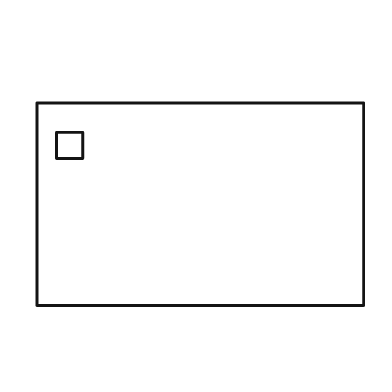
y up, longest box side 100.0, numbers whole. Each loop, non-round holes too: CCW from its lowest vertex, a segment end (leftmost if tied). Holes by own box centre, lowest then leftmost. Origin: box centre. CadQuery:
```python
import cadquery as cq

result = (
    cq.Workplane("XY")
    .moveTo(-50.0, -31.0)
    .lineTo(50.0, -31.0)
    .lineTo(50.0, 31.0)
    .lineTo(-50.0, 31.0)
    .close()
    .moveTo(-44.0, 14.0)
    .lineTo(-36.0, 14.0)
    .lineTo(-36.0, 22.0)
    .lineTo(-44.0, 22.0)
    .close()
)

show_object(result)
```